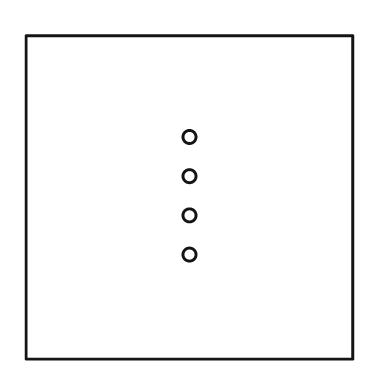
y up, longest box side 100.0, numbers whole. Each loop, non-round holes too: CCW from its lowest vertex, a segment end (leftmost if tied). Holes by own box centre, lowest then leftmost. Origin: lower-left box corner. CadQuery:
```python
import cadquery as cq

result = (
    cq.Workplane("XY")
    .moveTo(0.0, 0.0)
    .lineTo(100.0, 0.0)
    .lineTo(100.0, 99.0)
    .lineTo(0.0, 99.0)
    .close()
    .moveTo(50.0, 32.0)
    .circle(2.0)
    .moveTo(50.0, 44.0)
    .circle(2.0)
    .moveTo(50.0, 56.0)
    .circle(2.0)
    .moveTo(50.0, 68.0)
    .circle(2.0)
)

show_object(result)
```